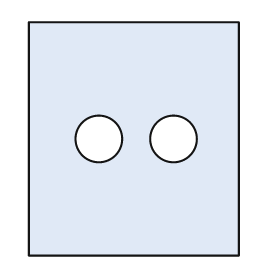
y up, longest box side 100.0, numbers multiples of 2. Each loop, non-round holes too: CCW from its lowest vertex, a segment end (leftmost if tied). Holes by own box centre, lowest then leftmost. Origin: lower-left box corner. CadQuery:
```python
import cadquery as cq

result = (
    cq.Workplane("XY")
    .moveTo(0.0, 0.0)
    .lineTo(90.0, 0.0)
    .lineTo(90.0, 100.0)
    .lineTo(0.0, 100.0)
    .close()
    .moveTo(30.0, 50.0)
    .circle(10.0)
    .moveTo(62.0, 50.0)
    .circle(10.0)
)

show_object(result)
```